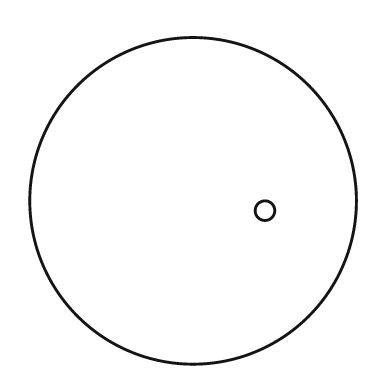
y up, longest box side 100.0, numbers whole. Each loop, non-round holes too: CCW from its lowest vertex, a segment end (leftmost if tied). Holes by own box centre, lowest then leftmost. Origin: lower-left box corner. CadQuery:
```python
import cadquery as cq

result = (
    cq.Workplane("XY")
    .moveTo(50.0, 50.0)
    .circle(50.0)
    .moveTo(72.0, 47.0)
    .circle(3.0)
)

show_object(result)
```